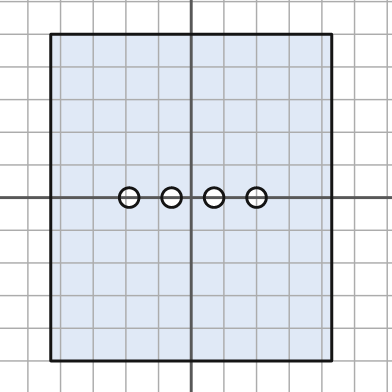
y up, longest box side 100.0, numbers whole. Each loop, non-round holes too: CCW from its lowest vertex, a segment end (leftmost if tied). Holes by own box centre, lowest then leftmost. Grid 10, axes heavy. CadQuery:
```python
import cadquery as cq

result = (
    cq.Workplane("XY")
    .moveTo(-43.0, -50.0)
    .lineTo(43.0, -50.0)
    .lineTo(43.0, 50.0)
    .lineTo(-43.0, 50.0)
    .close()
    .moveTo(-19.0, 0.0)
    .circle(3.0)
    .moveTo(-6.0, 0.0)
    .circle(3.0)
    .moveTo(7.0, 0.0)
    .circle(3.0)
    .moveTo(20.0, 0.0)
    .circle(3.0)
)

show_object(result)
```